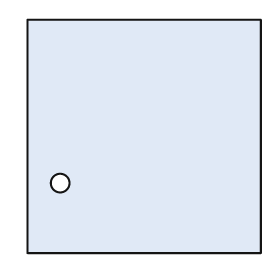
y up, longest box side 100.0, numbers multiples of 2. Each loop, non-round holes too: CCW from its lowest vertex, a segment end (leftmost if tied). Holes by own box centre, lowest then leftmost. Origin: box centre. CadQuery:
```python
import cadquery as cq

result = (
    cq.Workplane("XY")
    .moveTo(-50.0, -50.0)
    .lineTo(50.0, -50.0)
    .lineTo(50.0, 50.0)
    .lineTo(-50.0, 50.0)
    .close()
    .moveTo(-36.0, -20.0)
    .circle(4.0)
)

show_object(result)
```